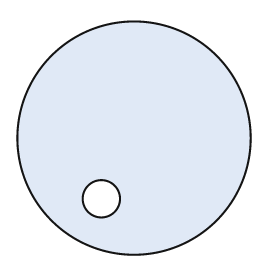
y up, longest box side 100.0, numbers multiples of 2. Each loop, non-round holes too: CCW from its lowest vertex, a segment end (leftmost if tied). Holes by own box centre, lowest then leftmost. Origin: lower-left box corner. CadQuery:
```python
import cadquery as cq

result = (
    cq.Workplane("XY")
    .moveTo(50.0, 50.0)
    .circle(50.0)
    .moveTo(36.0, 24.0)
    .circle(8.0)
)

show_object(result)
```